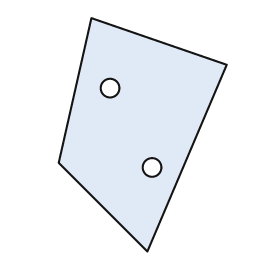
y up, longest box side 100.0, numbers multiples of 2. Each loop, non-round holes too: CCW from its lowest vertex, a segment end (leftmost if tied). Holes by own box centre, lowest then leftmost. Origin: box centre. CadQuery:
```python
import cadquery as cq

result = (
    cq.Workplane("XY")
    .moveTo(2.0, -50.0)
    .lineTo(36.0, 30.0)
    .lineTo(-22.0, 50.0)
    .lineTo(-36.0, -12.0)
    .close()
    .moveTo(4.0, -14.0)
    .circle(4.0)
    .moveTo(-14.0, 20.0)
    .circle(4.0)
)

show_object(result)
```